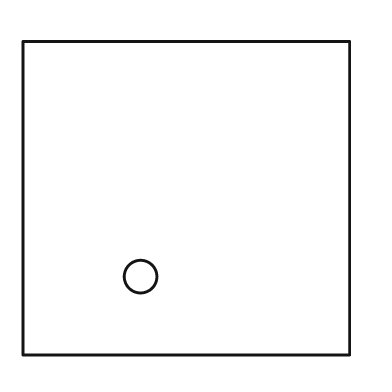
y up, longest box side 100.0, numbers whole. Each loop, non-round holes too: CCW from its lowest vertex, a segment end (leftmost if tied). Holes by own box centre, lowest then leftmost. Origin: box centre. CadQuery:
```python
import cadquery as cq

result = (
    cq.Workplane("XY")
    .moveTo(-50.0, -48.0)
    .lineTo(50.0, -48.0)
    .lineTo(50.0, 48.0)
    .lineTo(-50.0, 48.0)
    .close()
    .moveTo(-14.0, -24.0)
    .circle(5.0)
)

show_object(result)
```